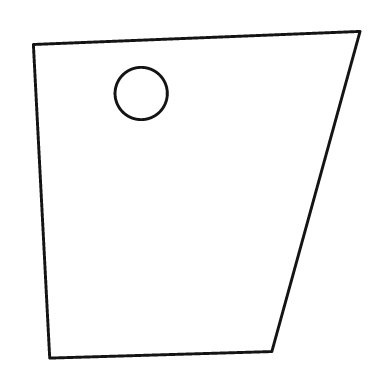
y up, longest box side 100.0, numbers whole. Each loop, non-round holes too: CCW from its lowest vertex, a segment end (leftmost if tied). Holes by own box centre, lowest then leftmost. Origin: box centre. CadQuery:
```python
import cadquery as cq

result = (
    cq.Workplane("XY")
    .moveTo(-45.0, -50.0)
    .lineTo(23.0, -48.0)
    .lineTo(50.0, 50.0)
    .lineTo(-50.0, 46.0)
    .close()
    .moveTo(-17.0, 31.0)
    .circle(8.0)
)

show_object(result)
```